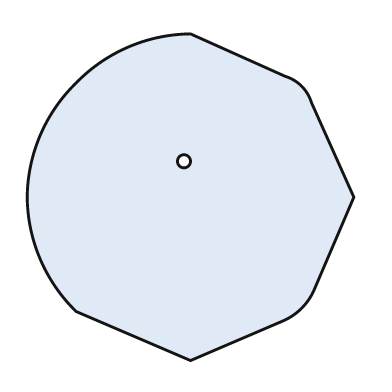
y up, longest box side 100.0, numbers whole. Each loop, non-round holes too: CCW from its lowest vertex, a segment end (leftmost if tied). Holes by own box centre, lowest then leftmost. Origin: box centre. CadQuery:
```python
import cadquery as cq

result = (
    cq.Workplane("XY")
    .moveTo(0.0, -50.0)
    .lineTo(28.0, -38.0)
    .threePointArc((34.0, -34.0), (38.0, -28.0))
    .lineTo(50.0, 0.0)
    .lineTo(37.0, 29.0)
    .threePointArc((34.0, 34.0), (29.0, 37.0))
    .lineTo(0.0, 50.0)
    .threePointArc((-19.0, 46.0), (-35.0, 35.0))
    .threePointArc((-46.0, 19.0), (-50.0, 0.0))
    .threePointArc((-46.0, -19.0), (-35.0, -35.0))
    .close()
    .moveTo(-2.0, 11.0)
    .circle(2.0)
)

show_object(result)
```